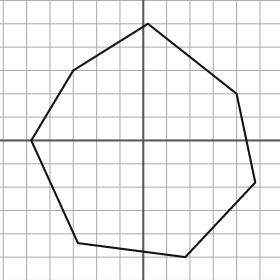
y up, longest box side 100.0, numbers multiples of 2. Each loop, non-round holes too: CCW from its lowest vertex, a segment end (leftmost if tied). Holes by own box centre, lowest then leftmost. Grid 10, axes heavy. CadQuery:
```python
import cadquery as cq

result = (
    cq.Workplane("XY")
    .moveTo(18.0, -50.0)
    .lineTo(48.0, -18.0)
    .lineTo(40.0, 20.0)
    .lineTo(2.0, 50.0)
    .lineTo(-30.0, 30.0)
    .lineTo(-48.0, 0.0)
    .lineTo(-28.0, -44.0)
    .close()
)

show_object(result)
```